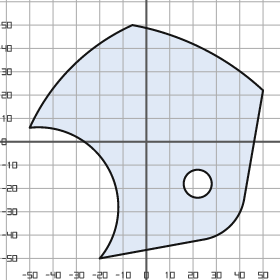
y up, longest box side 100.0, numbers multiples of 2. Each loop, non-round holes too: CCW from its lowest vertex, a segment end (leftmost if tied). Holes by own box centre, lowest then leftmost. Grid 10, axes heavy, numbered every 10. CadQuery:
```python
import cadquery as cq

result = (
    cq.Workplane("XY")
    .moveTo(-20.0, -50.0)
    .lineTo(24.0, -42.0)
    .threePointArc((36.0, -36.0), (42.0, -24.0))
    .lineTo(50.0, 22.0)
    .threePointArc((24.0, 40.0), (-6.0, 50.0))
    .threePointArc((-32.0, 32.0), (-50.0, 6.0))
    .threePointArc((-16.0, -12.0), (-20.0, -50.0))
    .close()
    .moveTo(22.0, -18.0)
    .circle(6.0)
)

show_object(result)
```